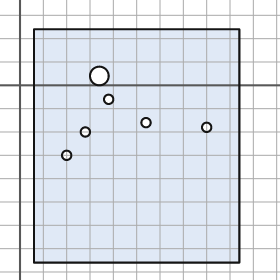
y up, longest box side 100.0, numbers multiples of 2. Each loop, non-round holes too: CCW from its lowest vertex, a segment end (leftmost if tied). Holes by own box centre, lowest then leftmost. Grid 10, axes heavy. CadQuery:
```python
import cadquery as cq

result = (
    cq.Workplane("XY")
    .moveTo(6.0, -76.0)
    .lineTo(94.0, -76.0)
    .lineTo(94.0, 24.0)
    .lineTo(6.0, 24.0)
    .close()
    .moveTo(20.0, -30.0)
    .circle(2.0)
    .moveTo(28.0, -20.0)
    .circle(2.0)
    .moveTo(80.0, -18.0)
    .circle(2.0)
    .moveTo(54.0, -16.0)
    .circle(2.0)
    .moveTo(38.0, -6.0)
    .circle(2.0)
    .moveTo(34.0, 4.0)
    .circle(4.0)
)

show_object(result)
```